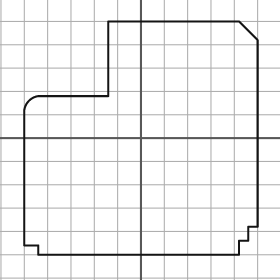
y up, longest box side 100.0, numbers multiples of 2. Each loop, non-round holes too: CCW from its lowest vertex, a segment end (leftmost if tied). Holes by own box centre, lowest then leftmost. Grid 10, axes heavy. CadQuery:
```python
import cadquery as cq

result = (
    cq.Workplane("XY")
    .moveTo(-44.0, -50.0)
    .lineTo(42.0, -50.0)
    .lineTo(42.0, -44.0)
    .lineTo(46.0, -44.0)
    .lineTo(46.0, -38.0)
    .lineTo(50.0, -38.0)
    .lineTo(50.0, 42.0)
    .lineTo(42.0, 50.0)
    .lineTo(-14.0, 50.0)
    .lineTo(-14.0, 18.0)
    .lineTo(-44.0, 18.0)
    .threePointArc((-48.0, 16.0), (-50.0, 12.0))
    .lineTo(-50.0, -46.0)
    .lineTo(-44.0, -46.0)
    .close()
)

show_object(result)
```